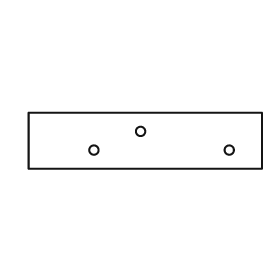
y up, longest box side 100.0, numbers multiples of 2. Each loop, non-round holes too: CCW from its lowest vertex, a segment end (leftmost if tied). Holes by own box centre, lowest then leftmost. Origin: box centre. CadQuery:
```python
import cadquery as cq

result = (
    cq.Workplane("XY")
    .moveTo(-50.0, -12.0)
    .lineTo(50.0, -12.0)
    .lineTo(50.0, 12.0)
    .lineTo(-50.0, 12.0)
    .close()
    .moveTo(-22.0, -4.0)
    .circle(2.0)
    .moveTo(36.0, -4.0)
    .circle(2.0)
    .moveTo(-2.0, 4.0)
    .circle(2.0)
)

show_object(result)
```